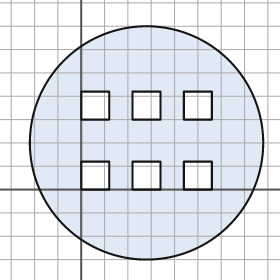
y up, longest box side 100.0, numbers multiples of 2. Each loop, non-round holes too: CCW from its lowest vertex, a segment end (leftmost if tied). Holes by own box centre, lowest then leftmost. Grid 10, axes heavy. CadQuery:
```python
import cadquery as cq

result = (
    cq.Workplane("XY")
    .moveTo(28.0, 20.0)
    .circle(50.0)
    .moveTo(0.0, 0.0)
    .lineTo(12.0, 0.0)
    .lineTo(12.0, 12.0)
    .lineTo(0.0, 12.0)
    .close()
    .moveTo(22.0, 0.0)
    .lineTo(34.0, 0.0)
    .lineTo(34.0, 12.0)
    .lineTo(22.0, 12.0)
    .close()
    .moveTo(44.0, 0.0)
    .lineTo(56.0, 0.0)
    .lineTo(56.0, 12.0)
    .lineTo(44.0, 12.0)
    .close()
    .moveTo(0.0, 30.0)
    .lineTo(12.0, 30.0)
    .lineTo(12.0, 42.0)
    .lineTo(0.0, 42.0)
    .close()
    .moveTo(22.0, 30.0)
    .lineTo(34.0, 30.0)
    .lineTo(34.0, 42.0)
    .lineTo(22.0, 42.0)
    .close()
    .moveTo(44.0, 30.0)
    .lineTo(56.0, 30.0)
    .lineTo(56.0, 42.0)
    .lineTo(44.0, 42.0)
    .close()
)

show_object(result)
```